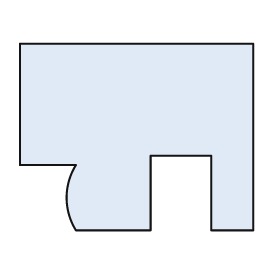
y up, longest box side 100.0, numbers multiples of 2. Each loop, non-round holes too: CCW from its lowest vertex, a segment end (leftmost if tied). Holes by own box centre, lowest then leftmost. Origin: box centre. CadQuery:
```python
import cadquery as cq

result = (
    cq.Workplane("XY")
    .moveTo(-26.0, -40.0)
    .lineTo(6.0, -40.0)
    .lineTo(6.0, -8.0)
    .lineTo(32.0, -8.0)
    .lineTo(32.0, -40.0)
    .lineTo(50.0, -40.0)
    .lineTo(50.0, 40.0)
    .lineTo(-50.0, 40.0)
    .lineTo(-50.0, -12.0)
    .lineTo(-26.0, -12.0)
    .threePointArc((-30.0, -26.0), (-26.0, -40.0))
    .close()
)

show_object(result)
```